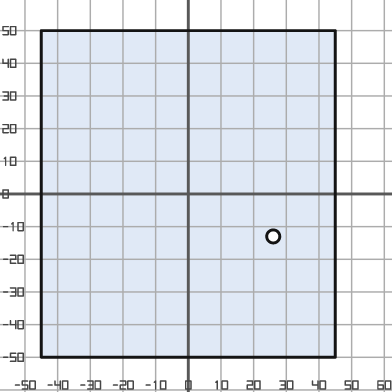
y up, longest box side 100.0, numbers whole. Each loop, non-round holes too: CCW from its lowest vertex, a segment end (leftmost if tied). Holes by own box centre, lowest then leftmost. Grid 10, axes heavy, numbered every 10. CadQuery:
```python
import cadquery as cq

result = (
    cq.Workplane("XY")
    .moveTo(-45.0, -50.0)
    .lineTo(45.0, -50.0)
    .lineTo(45.0, 50.0)
    .lineTo(-45.0, 50.0)
    .close()
    .moveTo(26.0, -13.0)
    .circle(2.0)
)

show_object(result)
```